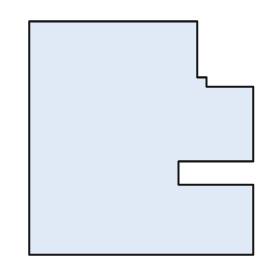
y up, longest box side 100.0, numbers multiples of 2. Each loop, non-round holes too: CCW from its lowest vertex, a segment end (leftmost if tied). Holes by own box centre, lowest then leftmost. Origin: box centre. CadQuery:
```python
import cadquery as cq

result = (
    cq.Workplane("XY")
    .moveTo(-48.0, -50.0)
    .lineTo(48.0, -50.0)
    .lineTo(48.0, -20.0)
    .lineTo(16.0, -20.0)
    .lineTo(16.0, -10.0)
    .lineTo(48.0, -10.0)
    .lineTo(48.0, 22.0)
    .lineTo(28.0, 22.0)
    .lineTo(28.0, 26.0)
    .lineTo(24.0, 26.0)
    .lineTo(24.0, 50.0)
    .lineTo(-48.0, 50.0)
    .close()
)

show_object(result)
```